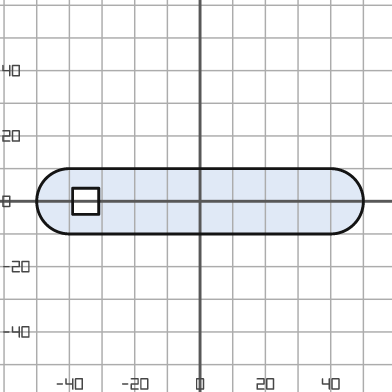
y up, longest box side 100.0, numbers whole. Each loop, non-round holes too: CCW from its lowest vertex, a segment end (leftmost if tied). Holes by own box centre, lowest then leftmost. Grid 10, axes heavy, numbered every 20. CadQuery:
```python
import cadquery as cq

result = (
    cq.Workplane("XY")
    .moveTo(-40.0, -10.0)
    .lineTo(40.0, -10.0)
    .threePointArc((50.0, 0.0), (40.0, 10.0))
    .lineTo(-40.0, 10.0)
    .threePointArc((-50.0, 0.0), (-40.0, -10.0))
    .close()
    .moveTo(-39.0, -4.0)
    .lineTo(-31.0, -4.0)
    .lineTo(-31.0, 4.0)
    .lineTo(-39.0, 4.0)
    .close()
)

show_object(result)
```